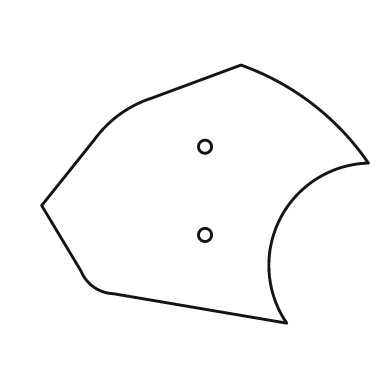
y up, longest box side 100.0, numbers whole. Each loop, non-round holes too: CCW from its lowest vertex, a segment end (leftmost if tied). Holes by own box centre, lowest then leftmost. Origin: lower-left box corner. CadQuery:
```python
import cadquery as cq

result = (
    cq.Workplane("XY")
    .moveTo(75.0, 0.0)
    .threePointArc((73.0, 32.0), (100.0, 49.0))
    .threePointArc((83.0, 67.0), (61.0, 79.0))
    .lineTo(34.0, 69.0)
    .threePointArc((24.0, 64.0), (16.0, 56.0))
    .lineTo(0.0, 36.0)
    .lineTo(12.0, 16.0)
    .threePointArc((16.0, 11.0), (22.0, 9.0))
    .close()
    .moveTo(50.0, 27.0)
    .circle(2.0)
    .moveTo(50.0, 54.0)
    .circle(2.0)
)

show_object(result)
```